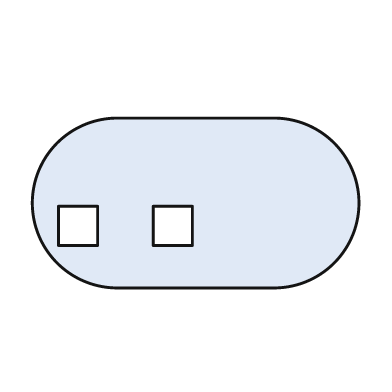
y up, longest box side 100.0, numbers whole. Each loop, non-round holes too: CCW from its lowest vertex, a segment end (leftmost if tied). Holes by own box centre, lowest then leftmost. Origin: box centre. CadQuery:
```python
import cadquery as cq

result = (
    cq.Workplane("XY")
    .moveTo(-24.0, -26.0)
    .lineTo(24.0, -26.0)
    .threePointArc((50.0, 0.0), (24.0, 26.0))
    .lineTo(-24.0, 26.0)
    .threePointArc((-50.0, 0.0), (-24.0, -26.0))
    .close()
    .moveTo(-42.0, -13.0)
    .lineTo(-30.0, -13.0)
    .lineTo(-30.0, -1.0)
    .lineTo(-42.0, -1.0)
    .close()
    .moveTo(-13.0, -13.0)
    .lineTo(-1.0, -13.0)
    .lineTo(-1.0, -1.0)
    .lineTo(-13.0, -1.0)
    .close()
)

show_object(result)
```